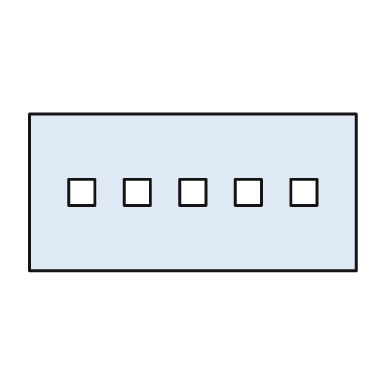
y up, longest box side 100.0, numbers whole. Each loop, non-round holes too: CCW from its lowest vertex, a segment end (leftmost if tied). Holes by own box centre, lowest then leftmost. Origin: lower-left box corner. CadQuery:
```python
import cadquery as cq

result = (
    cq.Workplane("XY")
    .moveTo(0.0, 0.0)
    .lineTo(100.0, 0.0)
    .lineTo(100.0, 48.0)
    .lineTo(0.0, 48.0)
    .close()
    .moveTo(12.0, 20.0)
    .lineTo(20.0, 20.0)
    .lineTo(20.0, 28.0)
    .lineTo(12.0, 28.0)
    .close()
    .moveTo(29.0, 20.0)
    .lineTo(37.0, 20.0)
    .lineTo(37.0, 28.0)
    .lineTo(29.0, 28.0)
    .close()
    .moveTo(46.0, 20.0)
    .lineTo(54.0, 20.0)
    .lineTo(54.0, 28.0)
    .lineTo(46.0, 28.0)
    .close()
    .moveTo(63.0, 20.0)
    .lineTo(71.0, 20.0)
    .lineTo(71.0, 28.0)
    .lineTo(63.0, 28.0)
    .close()
    .moveTo(80.0, 20.0)
    .lineTo(88.0, 20.0)
    .lineTo(88.0, 28.0)
    .lineTo(80.0, 28.0)
    .close()
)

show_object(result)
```